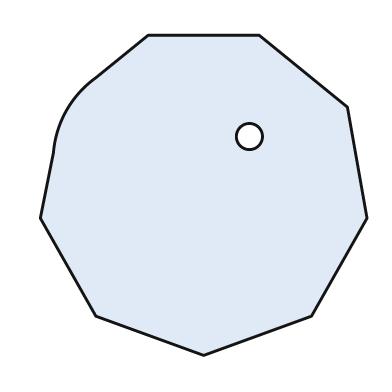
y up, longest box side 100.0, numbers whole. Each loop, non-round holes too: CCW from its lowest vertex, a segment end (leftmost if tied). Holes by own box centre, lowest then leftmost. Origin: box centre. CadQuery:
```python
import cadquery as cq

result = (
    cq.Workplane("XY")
    .moveTo(0.0, -49.0)
    .lineTo(33.0, -37.0)
    .lineTo(50.0, -7.0)
    .lineTo(44.0, 27.0)
    .lineTo(17.0, 49.0)
    .lineTo(-17.0, 49.0)
    .lineTo(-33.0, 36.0)
    .threePointArc((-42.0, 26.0), (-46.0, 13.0))
    .lineTo(-50.0, -7.0)
    .lineTo(-33.0, -37.0)
    .close()
    .moveTo(14.0, 18.0)
    .circle(4.0)
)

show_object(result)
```